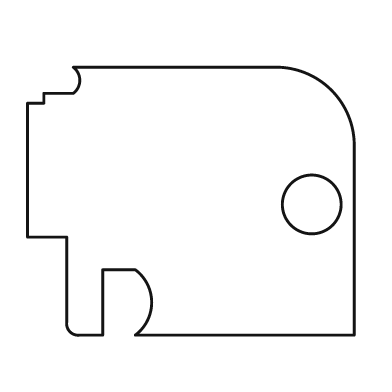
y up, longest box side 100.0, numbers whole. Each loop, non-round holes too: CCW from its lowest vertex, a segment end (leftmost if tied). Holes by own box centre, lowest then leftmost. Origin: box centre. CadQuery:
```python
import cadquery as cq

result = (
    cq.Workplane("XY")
    .moveTo(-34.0, -41.0)
    .lineTo(-27.0, -41.0)
    .lineTo(-27.0, -21.0)
    .lineTo(-17.0, -21.0)
    .threePointArc((-12.0, -31.0), (-17.0, -41.0))
    .lineTo(50.0, -41.0)
    .lineTo(50.0, 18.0)
    .threePointArc((43.0, 34.0), (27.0, 41.0))
    .lineTo(-36.0, 41.0)
    .threePointArc((-34.0, 37.0), (-36.0, 33.0))
    .lineTo(-45.0, 33.0)
    .lineTo(-45.0, 30.0)
    .lineTo(-50.0, 30.0)
    .lineTo(-50.0, -11.0)
    .lineTo(-38.0, -11.0)
    .lineTo(-38.0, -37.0)
    .threePointArc((-37.0, -40.0), (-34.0, -41.0))
    .close()
    .moveTo(37.0, -1.0)
    .circle(9.0)
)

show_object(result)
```